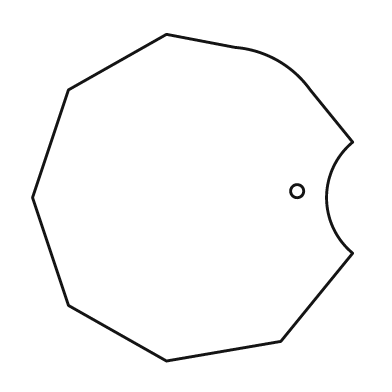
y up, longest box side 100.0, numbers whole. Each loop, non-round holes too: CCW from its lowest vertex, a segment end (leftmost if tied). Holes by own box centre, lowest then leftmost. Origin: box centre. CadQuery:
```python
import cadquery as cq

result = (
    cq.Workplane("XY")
    .moveTo(-8.0, -50.0)
    .lineTo(27.0, -44.0)
    .lineTo(49.0, -17.0)
    .threePointArc((41.0, 0.0), (49.0, 17.0))
    .lineTo(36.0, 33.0)
    .threePointArc((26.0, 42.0), (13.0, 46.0))
    .lineTo(-8.0, 50.0)
    .lineTo(-38.0, 33.0)
    .lineTo(-49.0, 0.0)
    .lineTo(-38.0, -33.0)
    .close()
    .moveTo(32.0, 2.0)
    .circle(2.0)
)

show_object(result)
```